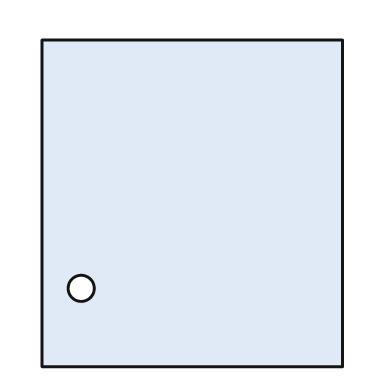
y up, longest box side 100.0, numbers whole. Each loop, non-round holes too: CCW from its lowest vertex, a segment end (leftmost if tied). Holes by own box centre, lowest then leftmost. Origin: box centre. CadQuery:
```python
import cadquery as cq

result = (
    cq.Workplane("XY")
    .moveTo(-46.0, -50.0)
    .lineTo(46.0, -50.0)
    .lineTo(46.0, 50.0)
    .lineTo(-46.0, 50.0)
    .close()
    .moveTo(-34.0, -26.0)
    .circle(4.0)
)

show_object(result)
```